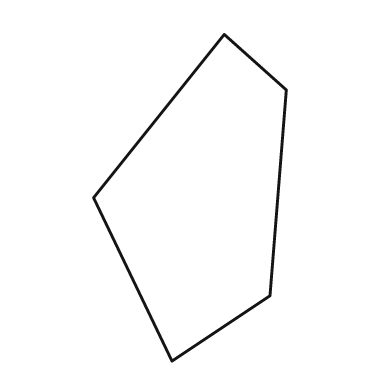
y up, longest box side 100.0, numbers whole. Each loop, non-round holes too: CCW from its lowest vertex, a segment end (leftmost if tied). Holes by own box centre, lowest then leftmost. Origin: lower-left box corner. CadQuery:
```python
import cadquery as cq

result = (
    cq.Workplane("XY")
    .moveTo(24.0, 0.0)
    .lineTo(54.0, 20.0)
    .lineTo(59.0, 83.0)
    .lineTo(40.0, 100.0)
    .lineTo(0.0, 50.0)
    .close()
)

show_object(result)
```